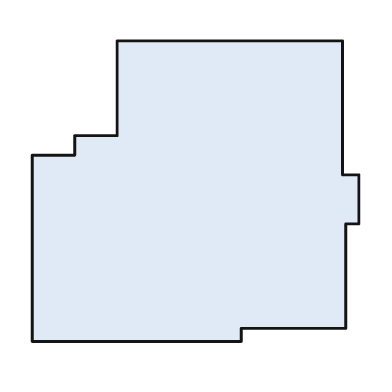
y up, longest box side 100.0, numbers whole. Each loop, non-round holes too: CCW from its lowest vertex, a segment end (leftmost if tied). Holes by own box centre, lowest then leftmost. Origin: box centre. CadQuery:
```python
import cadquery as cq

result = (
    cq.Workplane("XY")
    .moveTo(-50.0, -46.0)
    .lineTo(14.0, -46.0)
    .lineTo(14.0, -42.0)
    .lineTo(46.0, -42.0)
    .lineTo(46.0, -10.0)
    .lineTo(50.0, -10.0)
    .lineTo(50.0, 5.0)
    .lineTo(45.0, 5.0)
    .lineTo(45.0, 46.0)
    .lineTo(-24.0, 46.0)
    .lineTo(-24.0, 17.0)
    .lineTo(-37.0, 17.0)
    .lineTo(-37.0, 11.0)
    .lineTo(-50.0, 11.0)
    .close()
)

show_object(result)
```